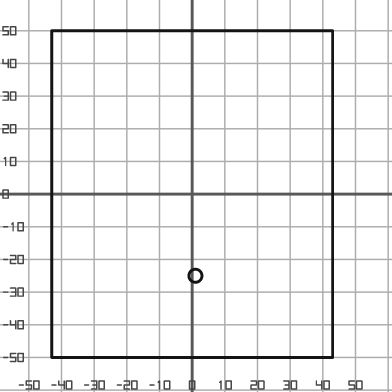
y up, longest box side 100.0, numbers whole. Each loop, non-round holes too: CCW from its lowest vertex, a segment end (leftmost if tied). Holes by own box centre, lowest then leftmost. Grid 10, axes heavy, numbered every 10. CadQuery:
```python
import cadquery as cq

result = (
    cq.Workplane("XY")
    .moveTo(-43.0, -50.0)
    .lineTo(43.0, -50.0)
    .lineTo(43.0, 50.0)
    .lineTo(-43.0, 50.0)
    .close()
    .moveTo(1.0, -25.0)
    .circle(2.0)
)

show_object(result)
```